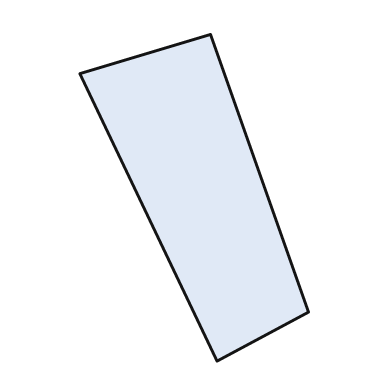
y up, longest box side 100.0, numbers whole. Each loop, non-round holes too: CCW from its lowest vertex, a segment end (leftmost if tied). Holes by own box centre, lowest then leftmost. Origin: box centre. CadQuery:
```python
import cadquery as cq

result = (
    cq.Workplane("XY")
    .moveTo(7.0, -50.0)
    .lineTo(35.0, -35.0)
    .lineTo(5.0, 50.0)
    .lineTo(-35.0, 38.0)
    .close()
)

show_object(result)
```